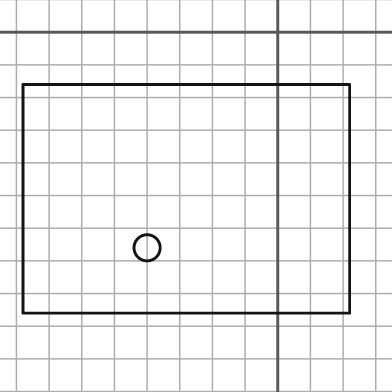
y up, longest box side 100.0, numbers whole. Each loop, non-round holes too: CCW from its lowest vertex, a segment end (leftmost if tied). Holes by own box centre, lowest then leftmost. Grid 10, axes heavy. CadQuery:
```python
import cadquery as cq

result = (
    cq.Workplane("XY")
    .moveTo(-78.0, -86.0)
    .lineTo(22.0, -86.0)
    .lineTo(22.0, -16.0)
    .lineTo(-78.0, -16.0)
    .close()
    .moveTo(-40.0, -66.0)
    .circle(4.0)
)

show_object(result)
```